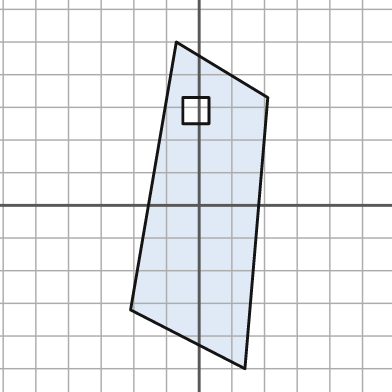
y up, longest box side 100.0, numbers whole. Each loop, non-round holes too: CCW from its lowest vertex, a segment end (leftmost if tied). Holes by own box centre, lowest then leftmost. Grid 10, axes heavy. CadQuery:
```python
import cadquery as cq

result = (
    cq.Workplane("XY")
    .moveTo(14.0, -50.0)
    .lineTo(21.0, 33.0)
    .lineTo(-7.0, 50.0)
    .lineTo(-21.0, -32.0)
    .close()
    .moveTo(-5.0, 25.0)
    .lineTo(3.0, 25.0)
    .lineTo(3.0, 33.0)
    .lineTo(-5.0, 33.0)
    .close()
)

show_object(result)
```